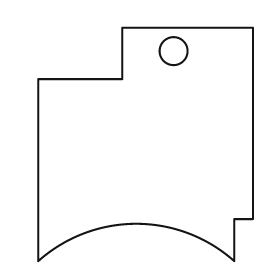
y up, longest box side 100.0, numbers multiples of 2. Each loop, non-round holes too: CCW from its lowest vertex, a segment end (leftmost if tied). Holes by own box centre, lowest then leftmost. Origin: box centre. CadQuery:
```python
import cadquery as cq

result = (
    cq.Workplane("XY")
    .moveTo(-46.0, -50.0)
    .threePointArc((-4.0, -34.0), (38.0, -50.0))
    .lineTo(38.0, -32.0)
    .lineTo(46.0, -32.0)
    .lineTo(46.0, 50.0)
    .lineTo(-10.0, 50.0)
    .lineTo(-10.0, 28.0)
    .lineTo(-46.0, 28.0)
    .close()
    .moveTo(12.0, 40.0)
    .circle(6.0)
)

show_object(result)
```